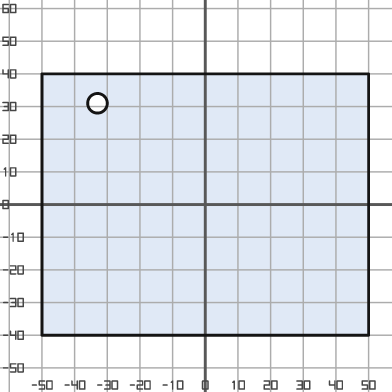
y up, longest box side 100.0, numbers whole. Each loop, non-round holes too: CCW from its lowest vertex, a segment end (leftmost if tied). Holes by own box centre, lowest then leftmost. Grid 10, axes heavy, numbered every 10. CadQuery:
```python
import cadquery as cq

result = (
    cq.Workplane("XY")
    .moveTo(-50.0, -40.0)
    .lineTo(50.0, -40.0)
    .lineTo(50.0, 40.0)
    .lineTo(-50.0, 40.0)
    .close()
    .moveTo(-33.0, 31.0)
    .circle(3.0)
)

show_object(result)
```